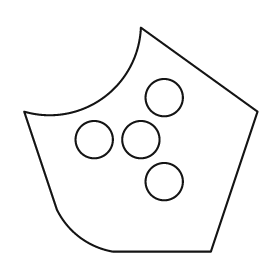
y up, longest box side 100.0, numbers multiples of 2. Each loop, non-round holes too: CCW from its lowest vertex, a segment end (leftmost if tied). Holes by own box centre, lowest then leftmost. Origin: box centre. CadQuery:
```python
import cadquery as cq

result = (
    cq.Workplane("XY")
    .moveTo(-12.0, -48.0)
    .lineTo(30.0, -48.0)
    .lineTo(50.0, 12.0)
    .lineTo(0.0, 48.0)
    .threePointArc((-16.0, 18.0), (-50.0, 12.0))
    .lineTo(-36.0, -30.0)
    .threePointArc((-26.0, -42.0), (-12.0, -48.0))
    .close()
    .moveTo(10.0, -18.0)
    .circle(8.0)
    .moveTo(-20.0, 0.0)
    .circle(8.0)
    .moveTo(0.0, 0.0)
    .circle(8.0)
    .moveTo(10.0, 18.0)
    .circle(8.0)
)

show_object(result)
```